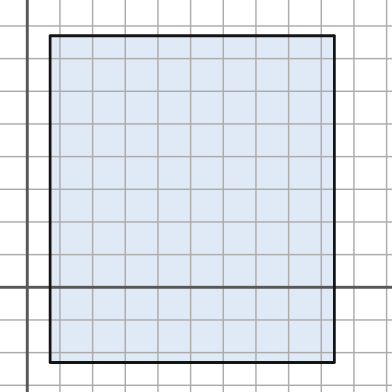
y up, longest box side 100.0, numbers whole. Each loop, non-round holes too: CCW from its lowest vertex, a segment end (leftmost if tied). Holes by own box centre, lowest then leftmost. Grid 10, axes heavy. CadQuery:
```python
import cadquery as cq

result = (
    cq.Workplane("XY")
    .moveTo(7.0, -23.0)
    .lineTo(94.0, -23.0)
    .lineTo(94.0, 77.0)
    .lineTo(7.0, 77.0)
    .close()
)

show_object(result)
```